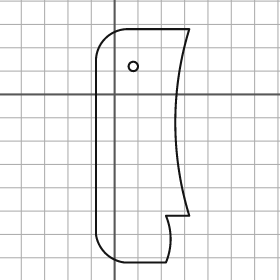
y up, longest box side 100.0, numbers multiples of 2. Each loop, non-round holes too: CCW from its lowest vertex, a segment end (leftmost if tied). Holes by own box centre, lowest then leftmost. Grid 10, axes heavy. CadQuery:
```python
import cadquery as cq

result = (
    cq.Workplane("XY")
    .moveTo(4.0, -72.0)
    .lineTo(22.0, -72.0)
    .threePointArc((24.0, -62.0), (22.0, -52.0))
    .lineTo(32.0, -52.0)
    .threePointArc((26.0, -12.0), (32.0, 28.0))
    .lineTo(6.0, 28.0)
    .threePointArc((-4.0, 24.0), (-8.0, 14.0))
    .lineTo(-8.0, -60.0)
    .threePointArc((-4.0, -68.0), (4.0, -72.0))
    .close()
    .moveTo(8.0, 12.0)
    .circle(2.0)
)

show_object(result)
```